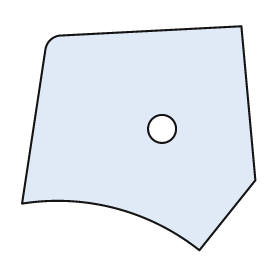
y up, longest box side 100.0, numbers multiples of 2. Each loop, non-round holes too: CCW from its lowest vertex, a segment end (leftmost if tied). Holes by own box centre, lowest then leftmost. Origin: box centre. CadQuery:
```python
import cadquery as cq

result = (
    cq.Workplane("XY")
    .moveTo(26.0, -48.0)
    .lineTo(50.0, -18.0)
    .lineTo(44.0, 48.0)
    .lineTo(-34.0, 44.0)
    .threePointArc((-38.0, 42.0), (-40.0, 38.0))
    .lineTo(-50.0, -28.0)
    .threePointArc((-10.0, -30.0), (26.0, -48.0))
    .close()
    .moveTo(10.0, 4.0)
    .circle(6.0)
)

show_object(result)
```